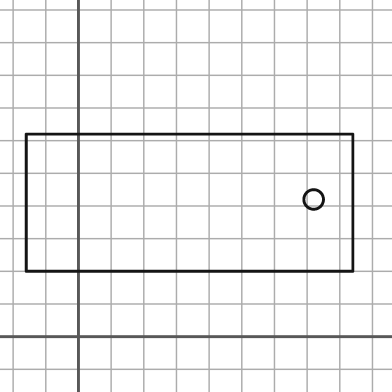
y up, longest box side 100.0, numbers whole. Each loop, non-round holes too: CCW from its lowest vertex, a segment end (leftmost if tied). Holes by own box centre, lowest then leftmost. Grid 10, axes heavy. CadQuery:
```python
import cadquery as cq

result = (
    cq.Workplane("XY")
    .moveTo(-16.0, 20.0)
    .lineTo(84.0, 20.0)
    .lineTo(84.0, 62.0)
    .lineTo(-16.0, 62.0)
    .close()
    .moveTo(72.0, 42.0)
    .circle(3.0)
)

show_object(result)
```